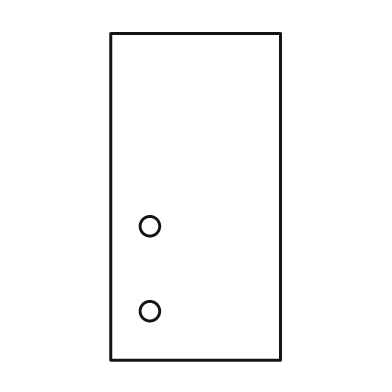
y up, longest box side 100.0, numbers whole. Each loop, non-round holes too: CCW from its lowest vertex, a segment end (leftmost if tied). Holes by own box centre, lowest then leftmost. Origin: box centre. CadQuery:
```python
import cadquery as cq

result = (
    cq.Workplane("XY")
    .moveTo(-26.0, -50.0)
    .lineTo(26.0, -50.0)
    .lineTo(26.0, 50.0)
    .lineTo(-26.0, 50.0)
    .close()
    .moveTo(-14.0, -35.0)
    .circle(3.0)
    .moveTo(-14.0, -9.0)
    .circle(3.0)
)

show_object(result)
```